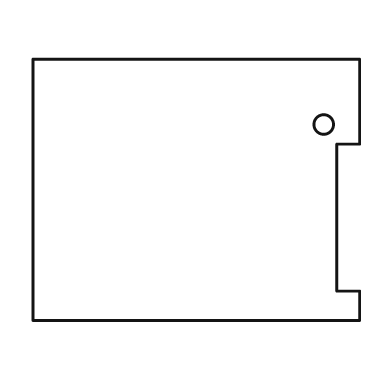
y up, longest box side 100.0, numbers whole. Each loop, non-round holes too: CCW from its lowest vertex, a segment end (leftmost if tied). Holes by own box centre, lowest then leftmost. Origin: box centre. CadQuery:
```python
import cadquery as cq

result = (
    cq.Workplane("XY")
    .moveTo(-50.0, -40.0)
    .lineTo(50.0, -40.0)
    .lineTo(50.0, -31.0)
    .lineTo(43.0, -31.0)
    .lineTo(43.0, 14.0)
    .lineTo(50.0, 14.0)
    .lineTo(50.0, 40.0)
    .lineTo(-50.0, 40.0)
    .close()
    .moveTo(39.0, 20.0)
    .circle(3.0)
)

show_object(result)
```